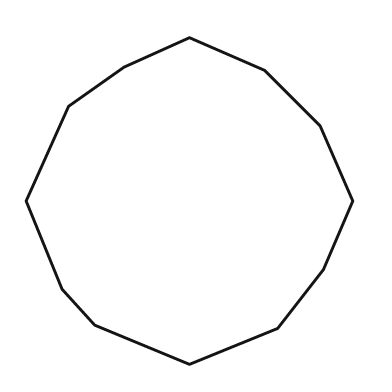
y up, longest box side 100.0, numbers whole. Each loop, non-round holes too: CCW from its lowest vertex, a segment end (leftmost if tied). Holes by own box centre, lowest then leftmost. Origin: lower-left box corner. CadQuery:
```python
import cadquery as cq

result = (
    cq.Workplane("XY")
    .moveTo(50.0, 0.0)
    .lineTo(77.0, 11.0)
    .lineTo(91.0, 29.0)
    .lineTo(100.0, 50.0)
    .lineTo(90.0, 73.0)
    .lineTo(73.0, 90.0)
    .lineTo(50.0, 100.0)
    .lineTo(30.0, 91.0)
    .lineTo(13.0, 79.0)
    .lineTo(0.0, 50.0)
    .lineTo(11.0, 23.0)
    .lineTo(21.0, 12.0)
    .close()
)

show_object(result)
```